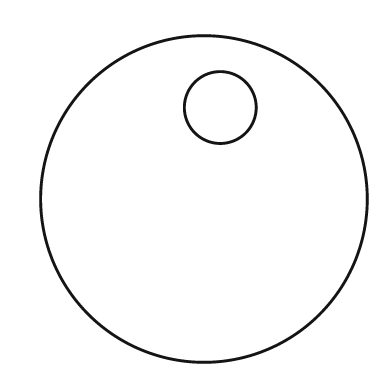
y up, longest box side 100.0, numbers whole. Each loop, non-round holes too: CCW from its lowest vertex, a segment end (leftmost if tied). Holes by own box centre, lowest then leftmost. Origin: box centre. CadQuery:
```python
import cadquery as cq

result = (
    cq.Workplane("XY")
    .moveTo(0.0, 0.0)
    .circle(50.0)
    .moveTo(5.0, 28.0)
    .circle(11.0)
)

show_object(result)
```